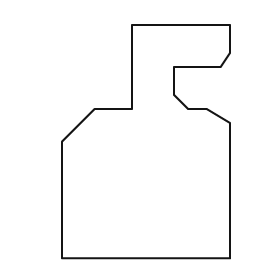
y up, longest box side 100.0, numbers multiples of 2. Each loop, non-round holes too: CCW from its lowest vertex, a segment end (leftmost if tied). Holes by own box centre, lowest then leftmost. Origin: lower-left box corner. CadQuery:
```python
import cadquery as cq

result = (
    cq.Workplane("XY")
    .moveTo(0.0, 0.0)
    .lineTo(72.0, 0.0)
    .lineTo(72.0, 58.0)
    .lineTo(62.0, 64.0)
    .lineTo(54.0, 64.0)
    .lineTo(48.0, 70.0)
    .lineTo(48.0, 82.0)
    .lineTo(68.0, 82.0)
    .lineTo(72.0, 88.0)
    .lineTo(72.0, 100.0)
    .lineTo(30.0, 100.0)
    .lineTo(30.0, 64.0)
    .lineTo(14.0, 64.0)
    .lineTo(0.0, 50.0)
    .close()
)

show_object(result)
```